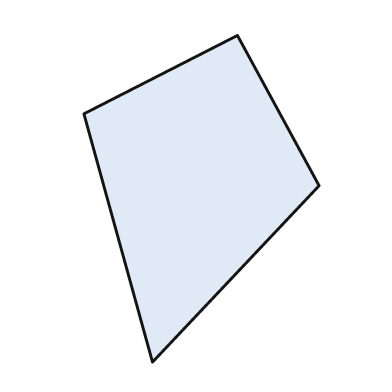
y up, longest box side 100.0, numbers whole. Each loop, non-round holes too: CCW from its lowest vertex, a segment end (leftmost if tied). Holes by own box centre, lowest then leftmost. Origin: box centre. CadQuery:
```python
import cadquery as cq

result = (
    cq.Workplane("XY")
    .moveTo(-15.0, -50.0)
    .lineTo(36.0, 4.0)
    .lineTo(11.0, 50.0)
    .lineTo(-36.0, 26.0)
    .close()
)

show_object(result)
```